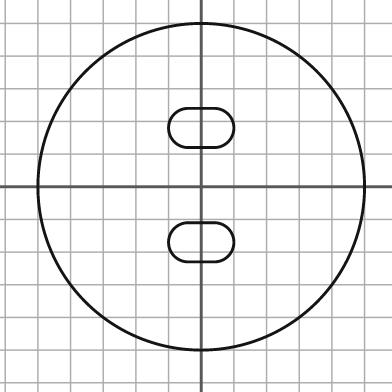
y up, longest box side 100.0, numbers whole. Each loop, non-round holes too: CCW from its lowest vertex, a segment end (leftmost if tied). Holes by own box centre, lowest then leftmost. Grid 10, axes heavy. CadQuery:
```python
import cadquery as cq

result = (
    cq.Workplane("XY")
    .moveTo(0.0, 0.0)
    .circle(50.0)
    .moveTo(-4.0, -23.0)
    .lineTo(4.0, -23.0)
    .threePointArc((10.0, -17.0), (4.0, -11.0))
    .lineTo(-4.0, -11.0)
    .threePointArc((-10.0, -17.0), (-4.0, -23.0))
    .close()
    .moveTo(-4.0, 12.0)
    .lineTo(4.0, 12.0)
    .threePointArc((10.0, 18.0), (4.0, 24.0))
    .lineTo(-4.0, 24.0)
    .threePointArc((-10.0, 18.0), (-4.0, 12.0))
    .close()
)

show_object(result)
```